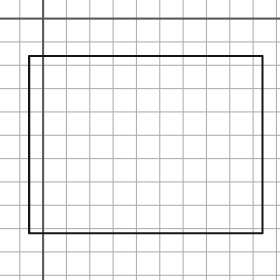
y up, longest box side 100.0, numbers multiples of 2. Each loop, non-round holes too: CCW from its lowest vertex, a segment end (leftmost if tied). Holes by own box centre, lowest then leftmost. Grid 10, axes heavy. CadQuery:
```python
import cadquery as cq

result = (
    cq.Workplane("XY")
    .moveTo(-6.0, -92.0)
    .lineTo(94.0, -92.0)
    .lineTo(94.0, -16.0)
    .lineTo(-6.0, -16.0)
    .close()
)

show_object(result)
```